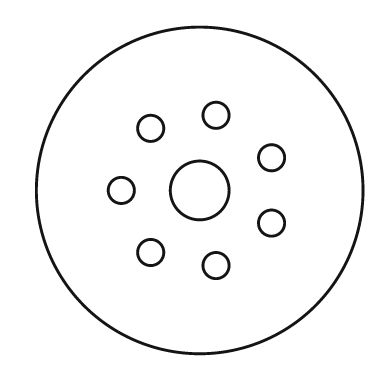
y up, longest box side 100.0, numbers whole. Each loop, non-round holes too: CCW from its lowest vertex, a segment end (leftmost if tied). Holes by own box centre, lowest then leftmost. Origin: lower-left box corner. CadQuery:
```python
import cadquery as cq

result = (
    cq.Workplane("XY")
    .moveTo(50.0, 50.0)
    .circle(50.0)
    .moveTo(55.0, 27.0)
    .circle(4.0)
    .moveTo(35.0, 31.0)
    .circle(4.0)
    .moveTo(72.0, 40.0)
    .circle(4.0)
    .moveTo(26.0, 50.0)
    .circle(4.0)
    .moveTo(50.0, 50.0)
    .circle(9.0)
    .moveTo(72.0, 60.0)
    .circle(4.0)
    .moveTo(35.0, 69.0)
    .circle(4.0)
    .moveTo(55.0, 73.0)
    .circle(4.0)
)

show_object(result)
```